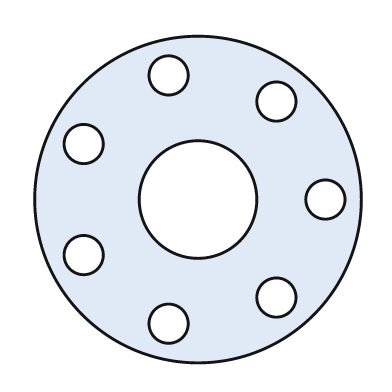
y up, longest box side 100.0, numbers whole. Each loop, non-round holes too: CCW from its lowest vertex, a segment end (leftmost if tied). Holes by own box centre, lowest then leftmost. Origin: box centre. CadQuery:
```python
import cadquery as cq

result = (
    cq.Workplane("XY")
    .moveTo(0.0, 0.0)
    .circle(50.0)
    .moveTo(-9.0, -38.0)
    .circle(6.0)
    .moveTo(24.0, -30.0)
    .circle(6.0)
    .moveTo(-35.0, -17.0)
    .circle(6.0)
    .moveTo(0.0, 0.0)
    .circle(18.0)
    .moveTo(39.0, 0.0)
    .circle(6.0)
    .moveTo(-35.0, 17.0)
    .circle(6.0)
    .moveTo(24.0, 30.0)
    .circle(6.0)
    .moveTo(-9.0, 38.0)
    .circle(6.0)
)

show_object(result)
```